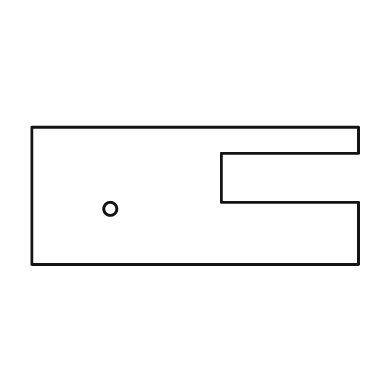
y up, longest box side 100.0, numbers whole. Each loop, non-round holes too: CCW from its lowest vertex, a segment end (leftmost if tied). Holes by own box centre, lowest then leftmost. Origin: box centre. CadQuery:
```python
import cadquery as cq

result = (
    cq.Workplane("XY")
    .moveTo(-50.0, -21.0)
    .lineTo(50.0, -21.0)
    .lineTo(50.0, -2.0)
    .lineTo(8.0, -2.0)
    .lineTo(8.0, 13.0)
    .lineTo(50.0, 13.0)
    .lineTo(50.0, 21.0)
    .lineTo(-50.0, 21.0)
    .close()
    .moveTo(-26.0, -4.0)
    .circle(2.0)
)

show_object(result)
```